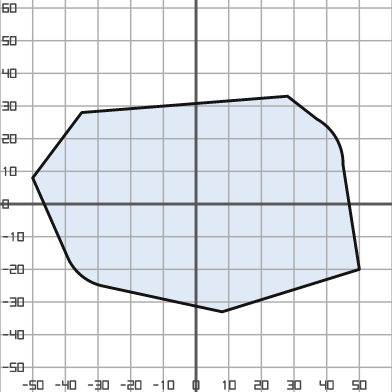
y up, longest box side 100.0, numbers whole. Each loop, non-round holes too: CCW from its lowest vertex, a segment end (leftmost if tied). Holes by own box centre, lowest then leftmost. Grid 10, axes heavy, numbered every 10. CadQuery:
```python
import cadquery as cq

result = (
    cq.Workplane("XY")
    .moveTo(8.0, -33.0)
    .lineTo(50.0, -20.0)
    .lineTo(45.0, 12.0)
    .threePointArc((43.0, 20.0), (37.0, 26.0))
    .lineTo(28.0, 33.0)
    .lineTo(-35.0, 28.0)
    .lineTo(-50.0, 8.0)
    .lineTo(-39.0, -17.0)
    .threePointArc((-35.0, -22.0), (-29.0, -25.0))
    .close()
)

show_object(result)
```